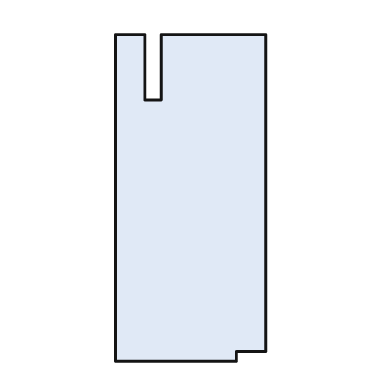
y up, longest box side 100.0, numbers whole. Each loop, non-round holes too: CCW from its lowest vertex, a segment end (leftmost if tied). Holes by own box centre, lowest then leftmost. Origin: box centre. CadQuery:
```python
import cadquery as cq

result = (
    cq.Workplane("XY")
    .moveTo(-23.0, -50.0)
    .lineTo(14.0, -50.0)
    .lineTo(14.0, -47.0)
    .lineTo(23.0, -47.0)
    .lineTo(23.0, 50.0)
    .lineTo(-9.0, 50.0)
    .lineTo(-9.0, 30.0)
    .lineTo(-14.0, 30.0)
    .lineTo(-14.0, 50.0)
    .lineTo(-23.0, 50.0)
    .close()
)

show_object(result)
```